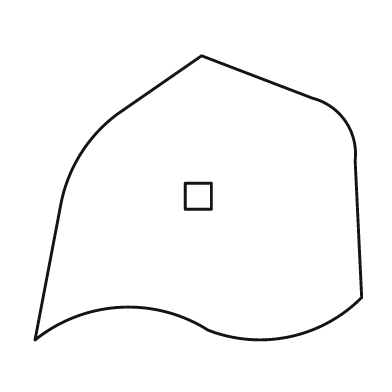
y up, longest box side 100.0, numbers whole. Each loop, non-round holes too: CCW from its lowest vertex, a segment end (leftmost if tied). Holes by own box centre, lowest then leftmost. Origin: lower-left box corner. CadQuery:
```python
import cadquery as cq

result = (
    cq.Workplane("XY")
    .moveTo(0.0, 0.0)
    .threePointArc((26.0, 10.0), (53.0, 3.0))
    .threePointArc((78.0, 1.0), (100.0, 13.0))
    .lineTo(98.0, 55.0)
    .threePointArc((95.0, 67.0), (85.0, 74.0))
    .lineTo(51.0, 87.0)
    .lineTo(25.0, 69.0)
    .threePointArc((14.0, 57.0), (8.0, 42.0))
    .close()
    .moveTo(46.0, 40.0)
    .lineTo(54.0, 40.0)
    .lineTo(54.0, 48.0)
    .lineTo(46.0, 48.0)
    .close()
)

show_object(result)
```